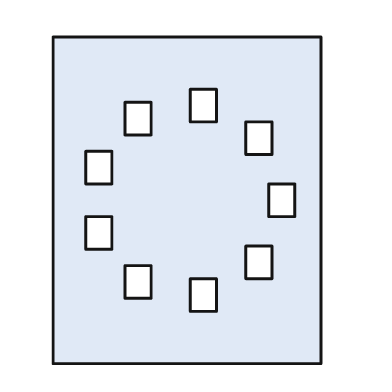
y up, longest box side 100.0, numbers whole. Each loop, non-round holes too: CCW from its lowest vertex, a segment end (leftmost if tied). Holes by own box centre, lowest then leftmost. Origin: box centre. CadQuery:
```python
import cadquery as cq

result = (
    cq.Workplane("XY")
    .moveTo(-41.0, -50.0)
    .lineTo(41.0, -50.0)
    .lineTo(41.0, 50.0)
    .lineTo(-41.0, 50.0)
    .close()
    .moveTo(1.0, -34.0)
    .lineTo(9.0, -34.0)
    .lineTo(9.0, -24.0)
    .lineTo(1.0, -24.0)
    .close()
    .moveTo(-19.0, -30.0)
    .lineTo(-11.0, -30.0)
    .lineTo(-11.0, -20.0)
    .lineTo(-19.0, -20.0)
    .close()
    .moveTo(18.0, -24.0)
    .lineTo(26.0, -24.0)
    .lineTo(26.0, -14.0)
    .lineTo(18.0, -14.0)
    .close()
    .moveTo(-31.0, -15.0)
    .lineTo(-23.0, -15.0)
    .lineTo(-23.0, -5.0)
    .lineTo(-31.0, -5.0)
    .close()
    .moveTo(25.0, -5.0)
    .lineTo(33.0, -5.0)
    .lineTo(33.0, 5.0)
    .lineTo(25.0, 5.0)
    .close()
    .moveTo(-31.0, 5.0)
    .lineTo(-23.0, 5.0)
    .lineTo(-23.0, 15.0)
    .lineTo(-31.0, 15.0)
    .close()
    .moveTo(18.0, 14.0)
    .lineTo(26.0, 14.0)
    .lineTo(26.0, 24.0)
    .lineTo(18.0, 24.0)
    .close()
    .moveTo(-19.0, 20.0)
    .lineTo(-11.0, 20.0)
    .lineTo(-11.0, 30.0)
    .lineTo(-19.0, 30.0)
    .close()
    .moveTo(1.0, 24.0)
    .lineTo(9.0, 24.0)
    .lineTo(9.0, 34.0)
    .lineTo(1.0, 34.0)
    .close()
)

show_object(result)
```